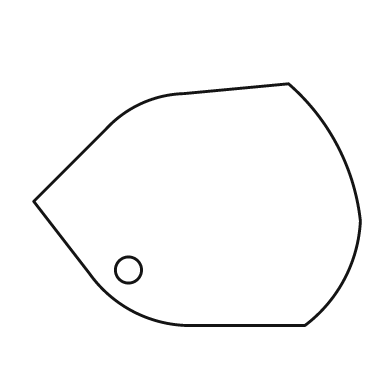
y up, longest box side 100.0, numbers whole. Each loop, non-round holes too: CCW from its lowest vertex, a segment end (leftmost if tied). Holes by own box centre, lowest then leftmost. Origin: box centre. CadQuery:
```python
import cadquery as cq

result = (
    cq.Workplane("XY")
    .moveTo(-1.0, -37.0)
    .lineTo(33.0, -37.0)
    .threePointArc((45.0, -23.0), (50.0, -5.0))
    .threePointArc((43.0, 18.0), (28.0, 37.0))
    .lineTo(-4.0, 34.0)
    .threePointArc((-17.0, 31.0), (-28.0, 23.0))
    .lineTo(-50.0, 1.0)
    .lineTo(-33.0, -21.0)
    .threePointArc((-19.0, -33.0), (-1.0, -37.0))
    .close()
    .moveTo(-21.0, -20.0)
    .circle(4.0)
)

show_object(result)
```